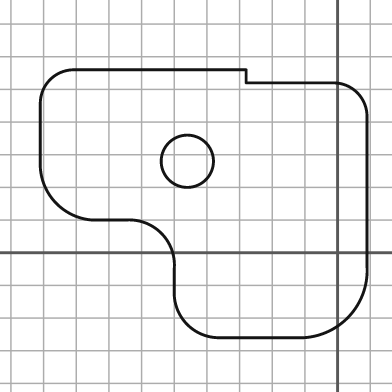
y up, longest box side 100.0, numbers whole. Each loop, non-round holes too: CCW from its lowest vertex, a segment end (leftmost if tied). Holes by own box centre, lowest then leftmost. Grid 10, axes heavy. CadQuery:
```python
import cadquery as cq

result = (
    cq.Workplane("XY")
    .moveTo(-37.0, -26.0)
    .lineTo(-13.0, -26.0)
    .threePointArc((3.0, -20.0), (9.0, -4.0))
    .lineTo(9.0, 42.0)
    .threePointArc((6.0, 49.0), (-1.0, 52.0))
    .lineTo(-28.0, 52.0)
    .lineTo(-28.0, 56.0)
    .lineTo(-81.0, 56.0)
    .threePointArc((-88.0, 53.0), (-91.0, 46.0))
    .lineTo(-91.0, 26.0)
    .threePointArc((-86.0, 15.0), (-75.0, 10.0))
    .lineTo(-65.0, 10.0)
    .threePointArc((-54.0, 6.0), (-50.0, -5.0))
    .lineTo(-50.0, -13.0)
    .threePointArc((-46.0, -22.0), (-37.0, -26.0))
    .close()
    .moveTo(-46.0, 28.0)
    .circle(8.0)
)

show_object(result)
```